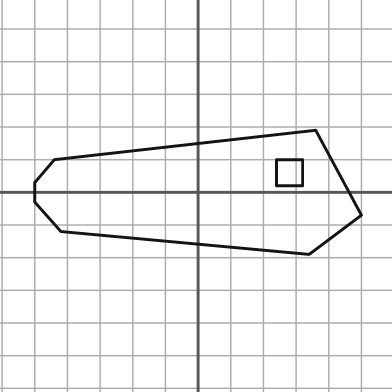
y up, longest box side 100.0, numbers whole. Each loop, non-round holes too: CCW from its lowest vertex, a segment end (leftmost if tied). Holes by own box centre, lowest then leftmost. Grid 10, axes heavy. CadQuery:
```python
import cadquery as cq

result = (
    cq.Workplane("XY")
    .moveTo(34.0, -19.0)
    .lineTo(50.0, -7.0)
    .lineTo(36.0, 19.0)
    .lineTo(-44.0, 10.0)
    .lineTo(-50.0, 3.0)
    .lineTo(-50.0, -3.0)
    .lineTo(-42.0, -12.0)
    .close()
    .moveTo(24.0, 2.0)
    .lineTo(32.0, 2.0)
    .lineTo(32.0, 10.0)
    .lineTo(24.0, 10.0)
    .close()
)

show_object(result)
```